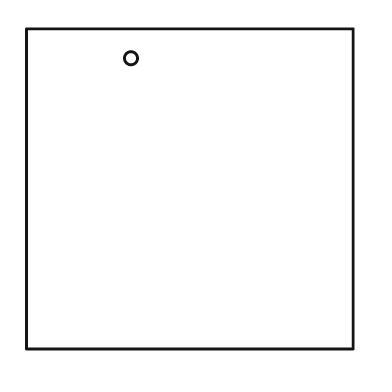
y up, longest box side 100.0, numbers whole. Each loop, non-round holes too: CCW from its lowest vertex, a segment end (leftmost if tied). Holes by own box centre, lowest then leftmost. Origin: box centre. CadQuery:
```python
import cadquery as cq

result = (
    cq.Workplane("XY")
    .moveTo(-50.0, -49.0)
    .lineTo(50.0, -49.0)
    .lineTo(50.0, 49.0)
    .lineTo(-50.0, 49.0)
    .close()
    .moveTo(-18.0, 40.0)
    .circle(2.0)
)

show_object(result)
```